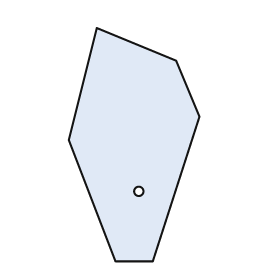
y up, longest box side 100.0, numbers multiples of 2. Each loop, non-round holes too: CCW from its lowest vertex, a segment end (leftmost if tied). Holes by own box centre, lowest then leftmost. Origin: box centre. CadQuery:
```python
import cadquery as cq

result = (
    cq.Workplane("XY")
    .moveTo(-8.0, -50.0)
    .lineTo(8.0, -50.0)
    .lineTo(28.0, 12.0)
    .lineTo(18.0, 36.0)
    .lineTo(-16.0, 50.0)
    .lineTo(-28.0, 2.0)
    .close()
    .moveTo(2.0, -20.0)
    .circle(2.0)
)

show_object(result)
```